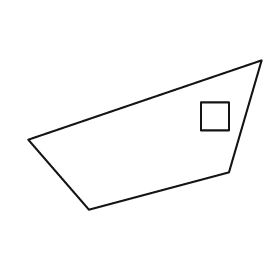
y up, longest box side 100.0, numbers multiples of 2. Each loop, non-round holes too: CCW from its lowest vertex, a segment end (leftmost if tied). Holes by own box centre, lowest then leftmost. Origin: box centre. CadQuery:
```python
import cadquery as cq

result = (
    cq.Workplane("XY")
    .moveTo(-24.0, -32.0)
    .lineTo(36.0, -16.0)
    .lineTo(50.0, 32.0)
    .lineTo(-50.0, -2.0)
    .close()
    .moveTo(24.0, 2.0)
    .lineTo(36.0, 2.0)
    .lineTo(36.0, 14.0)
    .lineTo(24.0, 14.0)
    .close()
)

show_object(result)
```